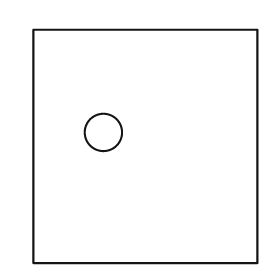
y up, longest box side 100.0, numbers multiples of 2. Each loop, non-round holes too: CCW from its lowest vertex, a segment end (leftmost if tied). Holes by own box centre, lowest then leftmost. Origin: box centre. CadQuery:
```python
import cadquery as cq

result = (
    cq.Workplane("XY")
    .moveTo(-48.0, -50.0)
    .lineTo(48.0, -50.0)
    .lineTo(48.0, 50.0)
    .lineTo(-48.0, 50.0)
    .close()
    .moveTo(-18.0, 6.0)
    .circle(8.0)
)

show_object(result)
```